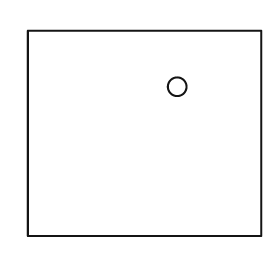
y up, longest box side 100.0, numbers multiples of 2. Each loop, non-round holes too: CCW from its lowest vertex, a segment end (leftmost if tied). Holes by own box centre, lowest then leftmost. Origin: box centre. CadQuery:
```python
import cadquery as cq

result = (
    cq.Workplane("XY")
    .moveTo(-50.0, -44.0)
    .lineTo(50.0, -44.0)
    .lineTo(50.0, 44.0)
    .lineTo(-50.0, 44.0)
    .close()
    .moveTo(14.0, 20.0)
    .circle(4.0)
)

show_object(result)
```